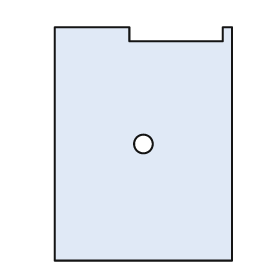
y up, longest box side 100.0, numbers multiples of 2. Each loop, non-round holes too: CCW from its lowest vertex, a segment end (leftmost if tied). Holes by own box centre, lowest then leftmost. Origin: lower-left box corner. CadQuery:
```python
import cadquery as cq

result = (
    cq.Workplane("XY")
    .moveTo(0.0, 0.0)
    .lineTo(76.0, 0.0)
    .lineTo(76.0, 100.0)
    .lineTo(72.0, 100.0)
    .lineTo(72.0, 94.0)
    .lineTo(32.0, 94.0)
    .lineTo(32.0, 100.0)
    .lineTo(0.0, 100.0)
    .close()
    .moveTo(38.0, 50.0)
    .circle(4.0)
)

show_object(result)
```